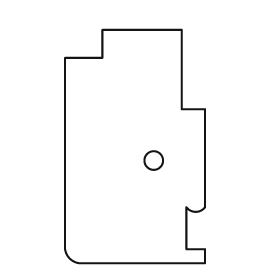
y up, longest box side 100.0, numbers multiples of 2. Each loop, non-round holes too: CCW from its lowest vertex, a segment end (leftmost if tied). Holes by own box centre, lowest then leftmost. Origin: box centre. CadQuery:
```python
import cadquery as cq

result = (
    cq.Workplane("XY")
    .moveTo(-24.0, -50.0)
    .lineTo(30.0, -50.0)
    .lineTo(30.0, -44.0)
    .lineTo(22.0, -44.0)
    .lineTo(22.0, -26.0)
    .threePointArc((26.0, -28.0), (30.0, -26.0))
    .lineTo(30.0, 16.0)
    .lineTo(20.0, 16.0)
    .lineTo(20.0, 50.0)
    .lineTo(-14.0, 50.0)
    .lineTo(-14.0, 38.0)
    .lineTo(-30.0, 38.0)
    .lineTo(-30.0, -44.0)
    .threePointArc((-28.0, -48.0), (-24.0, -50.0))
    .close()
    .moveTo(8.0, -6.0)
    .circle(4.0)
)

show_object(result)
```